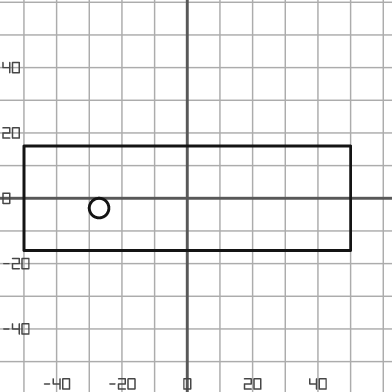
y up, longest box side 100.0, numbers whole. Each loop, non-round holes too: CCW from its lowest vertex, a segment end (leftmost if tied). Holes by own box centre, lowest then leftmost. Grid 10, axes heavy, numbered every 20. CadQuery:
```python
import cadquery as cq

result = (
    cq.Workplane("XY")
    .moveTo(-50.0, -16.0)
    .lineTo(50.0, -16.0)
    .lineTo(50.0, 16.0)
    .lineTo(-50.0, 16.0)
    .close()
    .moveTo(-27.0, -3.0)
    .circle(3.0)
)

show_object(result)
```